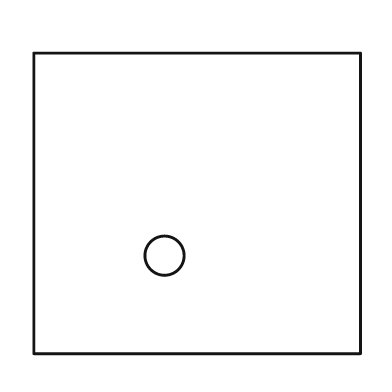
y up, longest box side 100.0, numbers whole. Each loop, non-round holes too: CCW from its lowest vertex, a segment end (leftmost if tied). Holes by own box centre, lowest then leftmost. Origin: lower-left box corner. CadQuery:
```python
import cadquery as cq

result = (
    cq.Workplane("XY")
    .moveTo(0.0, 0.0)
    .lineTo(100.0, 0.0)
    .lineTo(100.0, 92.0)
    .lineTo(0.0, 92.0)
    .close()
    .moveTo(40.0, 30.0)
    .circle(6.0)
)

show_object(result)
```